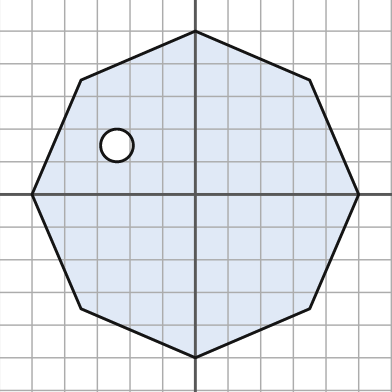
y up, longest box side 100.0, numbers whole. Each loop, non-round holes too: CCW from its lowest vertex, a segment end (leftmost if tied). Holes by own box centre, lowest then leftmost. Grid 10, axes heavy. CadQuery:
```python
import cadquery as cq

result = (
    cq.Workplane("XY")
    .moveTo(0.0, -50.0)
    .lineTo(35.0, -35.0)
    .lineTo(50.0, 0.0)
    .lineTo(35.0, 35.0)
    .lineTo(0.0, 50.0)
    .lineTo(-35.0, 35.0)
    .lineTo(-50.0, 0.0)
    .lineTo(-35.0, -35.0)
    .close()
    .moveTo(-24.0, 15.0)
    .circle(5.0)
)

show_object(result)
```